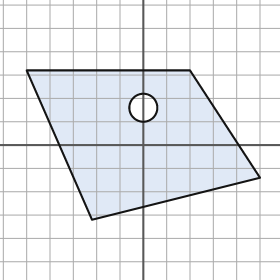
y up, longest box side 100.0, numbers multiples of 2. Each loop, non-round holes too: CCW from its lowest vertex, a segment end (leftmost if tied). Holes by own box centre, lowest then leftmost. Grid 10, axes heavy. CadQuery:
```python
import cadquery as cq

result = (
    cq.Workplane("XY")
    .moveTo(-22.0, -32.0)
    .lineTo(50.0, -14.0)
    .lineTo(20.0, 32.0)
    .lineTo(-50.0, 32.0)
    .close()
    .moveTo(0.0, 16.0)
    .circle(6.0)
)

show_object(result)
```